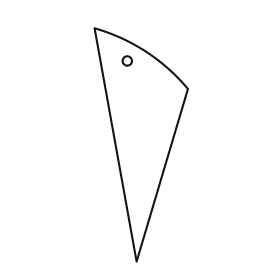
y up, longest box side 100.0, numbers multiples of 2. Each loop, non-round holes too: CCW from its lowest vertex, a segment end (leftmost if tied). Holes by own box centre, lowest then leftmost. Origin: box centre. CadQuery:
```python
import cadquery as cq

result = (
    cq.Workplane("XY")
    .moveTo(-2.0, -50.0)
    .lineTo(20.0, 24.0)
    .threePointArc((2.0, 40.0), (-20.0, 50.0))
    .close()
    .moveTo(-6.0, 36.0)
    .circle(2.0)
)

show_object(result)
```